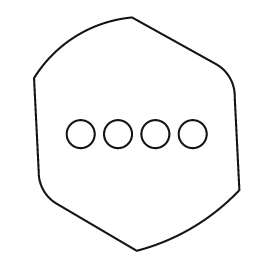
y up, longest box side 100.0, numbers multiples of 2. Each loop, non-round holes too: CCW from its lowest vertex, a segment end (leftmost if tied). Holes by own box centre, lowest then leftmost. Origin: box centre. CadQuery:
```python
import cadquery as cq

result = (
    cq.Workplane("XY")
    .moveTo(0.0, -50.0)
    .threePointArc((24.0, -40.0), (44.0, -24.0))
    .lineTo(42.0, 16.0)
    .threePointArc((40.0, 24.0), (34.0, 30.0))
    .lineTo(-2.0, 50.0)
    .threePointArc((-26.0, 42.0), (-44.0, 24.0))
    .lineTo(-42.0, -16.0)
    .threePointArc((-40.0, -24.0), (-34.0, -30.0))
    .close()
    .moveTo(-24.0, 0.0)
    .circle(6.0)
    .moveTo(-8.0, 0.0)
    .circle(6.0)
    .moveTo(8.0, 0.0)
    .circle(6.0)
    .moveTo(24.0, 0.0)
    .circle(6.0)
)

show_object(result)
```